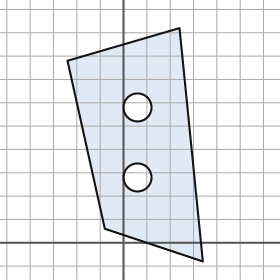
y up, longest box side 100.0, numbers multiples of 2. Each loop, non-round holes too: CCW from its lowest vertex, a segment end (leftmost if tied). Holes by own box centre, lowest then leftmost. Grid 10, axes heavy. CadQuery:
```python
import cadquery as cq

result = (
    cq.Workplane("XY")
    .moveTo(34.0, -8.0)
    .lineTo(24.0, 92.0)
    .lineTo(-24.0, 78.0)
    .lineTo(-8.0, 6.0)
    .close()
    .moveTo(6.0, 28.0)
    .circle(6.0)
    .moveTo(6.0, 58.0)
    .circle(6.0)
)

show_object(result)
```